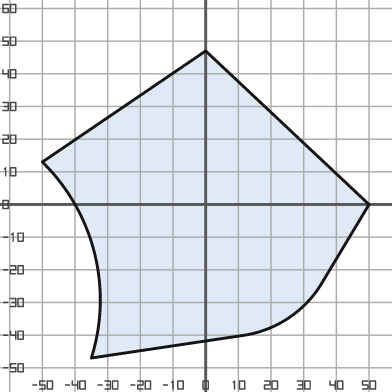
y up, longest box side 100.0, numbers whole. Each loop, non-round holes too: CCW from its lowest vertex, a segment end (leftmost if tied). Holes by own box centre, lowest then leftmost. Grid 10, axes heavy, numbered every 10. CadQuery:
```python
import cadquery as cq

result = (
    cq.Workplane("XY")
    .moveTo(-35.0, -47.0)
    .lineTo(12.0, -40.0)
    .threePointArc((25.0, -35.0), (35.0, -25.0))
    .lineTo(50.0, 0.0)
    .lineTo(0.0, 47.0)
    .lineTo(-50.0, 13.0)
    .threePointArc((-34.0, -15.0), (-35.0, -47.0))
    .close()
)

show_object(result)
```